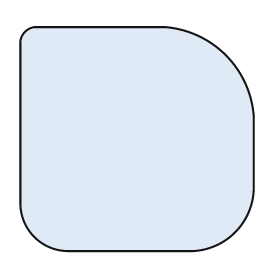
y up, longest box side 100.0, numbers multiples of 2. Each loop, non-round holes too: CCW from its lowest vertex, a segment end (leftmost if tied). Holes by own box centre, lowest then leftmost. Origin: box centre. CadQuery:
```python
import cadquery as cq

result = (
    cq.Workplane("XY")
    .moveTo(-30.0, -48.0)
    .lineTo(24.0, -48.0)
    .threePointArc((42.0, -40.0), (50.0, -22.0))
    .lineTo(50.0, 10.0)
    .threePointArc((38.0, 36.0), (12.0, 48.0))
    .lineTo(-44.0, 48.0)
    .threePointArc((-48.0, 46.0), (-50.0, 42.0))
    .lineTo(-50.0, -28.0)
    .threePointArc((-44.0, -42.0), (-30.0, -48.0))
    .close()
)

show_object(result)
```